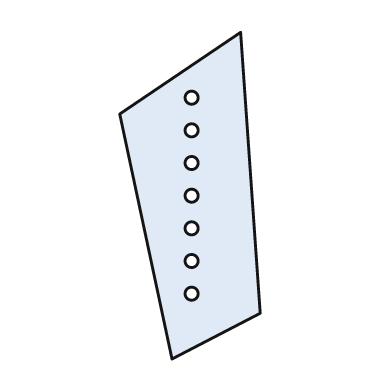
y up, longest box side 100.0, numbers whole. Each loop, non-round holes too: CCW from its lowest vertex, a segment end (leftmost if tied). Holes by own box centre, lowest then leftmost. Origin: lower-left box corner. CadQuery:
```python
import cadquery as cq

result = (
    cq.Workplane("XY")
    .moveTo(16.0, 0.0)
    .lineTo(43.0, 14.0)
    .lineTo(37.0, 100.0)
    .lineTo(0.0, 75.0)
    .close()
    .moveTo(22.0, 20.0)
    .circle(2.0)
    .moveTo(22.0, 30.0)
    .circle(2.0)
    .moveTo(22.0, 40.0)
    .circle(2.0)
    .moveTo(22.0, 50.0)
    .circle(2.0)
    .moveTo(22.0, 60.0)
    .circle(2.0)
    .moveTo(22.0, 70.0)
    .circle(2.0)
    .moveTo(22.0, 80.0)
    .circle(2.0)
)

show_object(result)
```